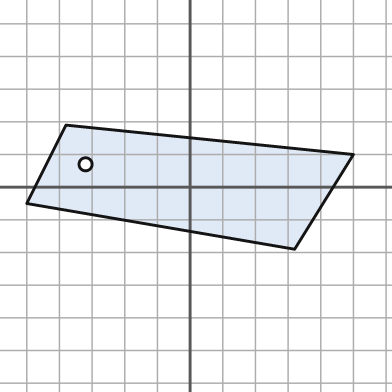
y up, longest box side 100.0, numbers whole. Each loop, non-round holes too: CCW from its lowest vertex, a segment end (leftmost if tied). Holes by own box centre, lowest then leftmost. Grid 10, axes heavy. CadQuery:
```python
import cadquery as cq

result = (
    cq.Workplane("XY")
    .moveTo(32.0, -19.0)
    .lineTo(50.0, 10.0)
    .lineTo(-38.0, 19.0)
    .lineTo(-50.0, -5.0)
    .close()
    .moveTo(-32.0, 7.0)
    .circle(2.0)
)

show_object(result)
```